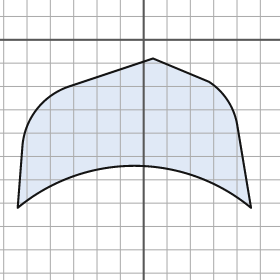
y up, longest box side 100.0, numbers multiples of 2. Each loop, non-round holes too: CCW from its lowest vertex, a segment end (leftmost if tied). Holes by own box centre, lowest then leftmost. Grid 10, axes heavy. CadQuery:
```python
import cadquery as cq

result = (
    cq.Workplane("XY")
    .moveTo(-54.0, -72.0)
    .threePointArc((-4.0, -54.0), (46.0, -72.0))
    .lineTo(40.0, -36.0)
    .threePointArc((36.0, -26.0), (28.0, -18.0))
    .lineTo(4.0, -8.0)
    .lineTo(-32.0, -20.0)
    .threePointArc((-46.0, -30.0), (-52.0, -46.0))
    .close()
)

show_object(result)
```